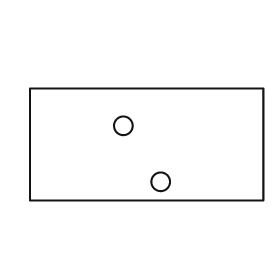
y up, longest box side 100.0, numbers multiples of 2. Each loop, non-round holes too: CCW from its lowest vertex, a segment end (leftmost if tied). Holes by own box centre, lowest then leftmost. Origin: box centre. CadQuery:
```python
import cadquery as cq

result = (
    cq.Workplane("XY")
    .moveTo(-50.0, -24.0)
    .lineTo(50.0, -24.0)
    .lineTo(50.0, 24.0)
    .lineTo(-50.0, 24.0)
    .close()
    .moveTo(6.0, -16.0)
    .circle(4.0)
    .moveTo(-10.0, 8.0)
    .circle(4.0)
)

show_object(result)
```